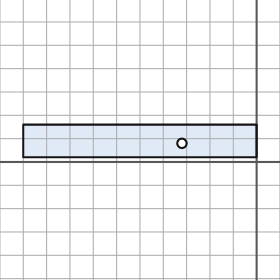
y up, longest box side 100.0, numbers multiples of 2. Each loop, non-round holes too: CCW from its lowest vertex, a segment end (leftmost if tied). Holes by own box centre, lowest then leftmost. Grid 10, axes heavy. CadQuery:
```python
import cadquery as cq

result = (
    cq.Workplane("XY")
    .moveTo(-100.0, 2.0)
    .lineTo(0.0, 2.0)
    .lineTo(0.0, 16.0)
    .lineTo(-100.0, 16.0)
    .close()
    .moveTo(-32.0, 8.0)
    .circle(2.0)
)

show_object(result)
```